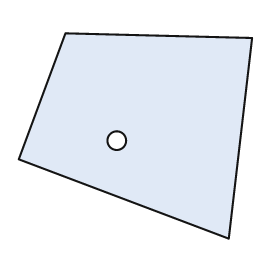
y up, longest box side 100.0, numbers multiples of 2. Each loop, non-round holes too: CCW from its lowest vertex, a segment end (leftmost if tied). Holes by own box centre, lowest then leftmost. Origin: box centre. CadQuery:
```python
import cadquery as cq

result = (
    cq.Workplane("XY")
    .moveTo(40.0, -44.0)
    .lineTo(50.0, 42.0)
    .lineTo(-30.0, 44.0)
    .lineTo(-50.0, -10.0)
    .close()
    .moveTo(-8.0, -2.0)
    .circle(4.0)
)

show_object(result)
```